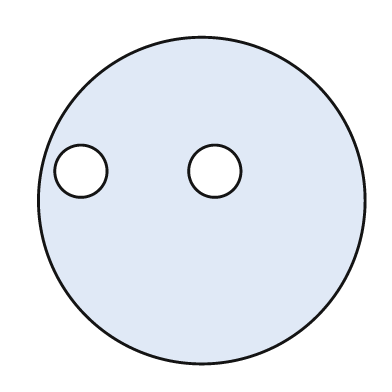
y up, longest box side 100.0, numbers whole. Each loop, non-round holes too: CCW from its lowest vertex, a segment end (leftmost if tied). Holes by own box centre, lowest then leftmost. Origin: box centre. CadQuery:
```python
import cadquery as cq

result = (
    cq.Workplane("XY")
    .moveTo(0.0, 0.0)
    .circle(50.0)
    .moveTo(-37.0, 9.0)
    .circle(8.0)
    .moveTo(4.0, 9.0)
    .circle(8.0)
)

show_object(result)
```